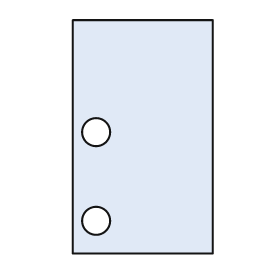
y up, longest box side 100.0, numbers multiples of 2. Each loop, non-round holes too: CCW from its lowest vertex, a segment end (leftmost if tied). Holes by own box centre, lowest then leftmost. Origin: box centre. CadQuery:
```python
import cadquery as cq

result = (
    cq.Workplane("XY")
    .moveTo(-30.0, -50.0)
    .lineTo(30.0, -50.0)
    .lineTo(30.0, 50.0)
    .lineTo(-30.0, 50.0)
    .close()
    .moveTo(-20.0, -36.0)
    .circle(6.0)
    .moveTo(-20.0, 2.0)
    .circle(6.0)
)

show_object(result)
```